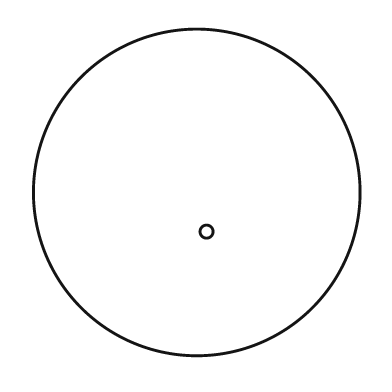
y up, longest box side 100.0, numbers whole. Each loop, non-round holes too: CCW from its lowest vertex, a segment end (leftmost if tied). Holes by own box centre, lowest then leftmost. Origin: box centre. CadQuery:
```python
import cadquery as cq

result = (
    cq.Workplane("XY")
    .moveTo(0.0, 0.0)
    .circle(50.0)
    .moveTo(3.0, -12.0)
    .circle(2.0)
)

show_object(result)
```